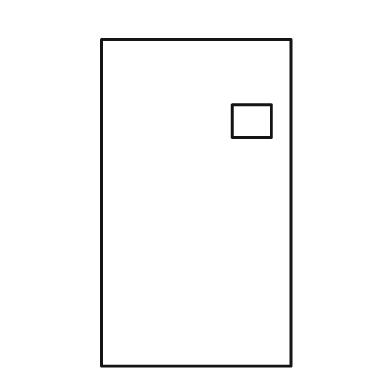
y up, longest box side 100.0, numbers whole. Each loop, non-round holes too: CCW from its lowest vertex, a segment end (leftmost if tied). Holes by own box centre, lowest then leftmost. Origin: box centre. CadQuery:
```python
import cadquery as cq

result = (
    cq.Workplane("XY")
    .moveTo(-29.0, -50.0)
    .lineTo(29.0, -50.0)
    .lineTo(29.0, 50.0)
    .lineTo(-29.0, 50.0)
    .close()
    .moveTo(11.0, 20.0)
    .lineTo(23.0, 20.0)
    .lineTo(23.0, 30.0)
    .lineTo(11.0, 30.0)
    .close()
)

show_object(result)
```